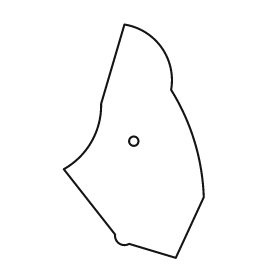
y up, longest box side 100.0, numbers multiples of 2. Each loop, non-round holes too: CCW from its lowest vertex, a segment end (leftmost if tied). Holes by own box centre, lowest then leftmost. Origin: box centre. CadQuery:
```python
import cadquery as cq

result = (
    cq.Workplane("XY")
    .moveTo(18.0, -50.0)
    .lineTo(30.0, -24.0)
    .threePointArc((26.0, 0.0), (16.0, 22.0))
    .threePointArc((12.0, 40.0), (-4.0, 50.0))
    .lineTo(-14.0, 16.0)
    .threePointArc((-18.0, 0.0), (-30.0, -12.0))
    .lineTo(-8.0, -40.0)
    .threePointArc((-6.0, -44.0), (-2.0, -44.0))
    .close()
    .moveTo(0.0, 0.0)
    .circle(2.0)
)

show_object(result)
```